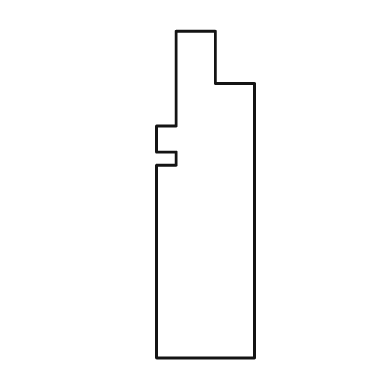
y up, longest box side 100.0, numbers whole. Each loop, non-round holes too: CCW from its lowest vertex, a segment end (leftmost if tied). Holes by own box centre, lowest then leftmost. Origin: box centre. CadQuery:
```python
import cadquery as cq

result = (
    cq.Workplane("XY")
    .moveTo(-15.0, -50.0)
    .lineTo(15.0, -50.0)
    .lineTo(15.0, 34.0)
    .lineTo(3.0, 34.0)
    .lineTo(3.0, 50.0)
    .lineTo(-9.0, 50.0)
    .lineTo(-9.0, 21.0)
    .lineTo(-15.0, 21.0)
    .lineTo(-15.0, 13.0)
    .lineTo(-9.0, 13.0)
    .lineTo(-9.0, 9.0)
    .lineTo(-15.0, 9.0)
    .close()
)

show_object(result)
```